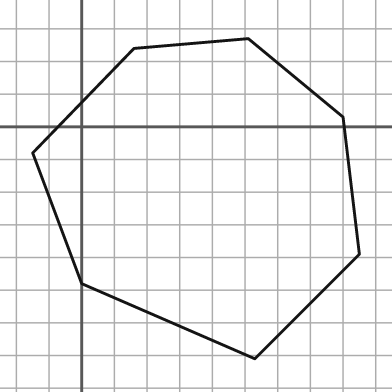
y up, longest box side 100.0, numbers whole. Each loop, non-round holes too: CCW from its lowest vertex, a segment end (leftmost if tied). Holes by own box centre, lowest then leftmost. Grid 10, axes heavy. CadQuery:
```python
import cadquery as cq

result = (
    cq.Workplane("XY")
    .moveTo(53.0, -71.0)
    .lineTo(85.0, -39.0)
    .lineTo(80.0, 3.0)
    .lineTo(51.0, 27.0)
    .lineTo(16.0, 24.0)
    .lineTo(-15.0, -8.0)
    .lineTo(0.0, -48.0)
    .close()
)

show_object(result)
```